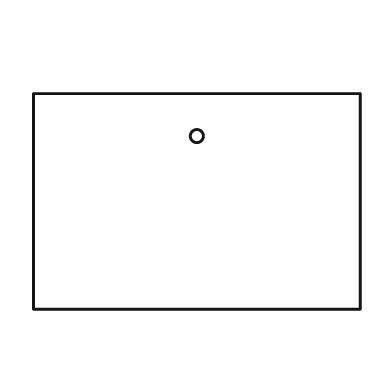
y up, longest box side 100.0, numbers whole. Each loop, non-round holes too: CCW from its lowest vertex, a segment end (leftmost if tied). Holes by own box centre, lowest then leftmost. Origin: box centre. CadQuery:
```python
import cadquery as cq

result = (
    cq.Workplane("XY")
    .moveTo(-50.0, -33.0)
    .lineTo(50.0, -33.0)
    .lineTo(50.0, 33.0)
    .lineTo(-50.0, 33.0)
    .close()
    .moveTo(0.0, 20.0)
    .circle(2.0)
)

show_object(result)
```